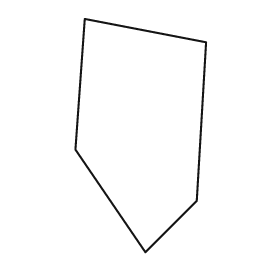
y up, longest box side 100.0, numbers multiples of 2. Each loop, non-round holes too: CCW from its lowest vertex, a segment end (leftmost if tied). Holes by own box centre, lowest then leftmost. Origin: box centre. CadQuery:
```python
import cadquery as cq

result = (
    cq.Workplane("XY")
    .moveTo(2.0, -50.0)
    .lineTo(24.0, -28.0)
    .lineTo(28.0, 40.0)
    .lineTo(-24.0, 50.0)
    .lineTo(-28.0, -6.0)
    .close()
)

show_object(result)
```